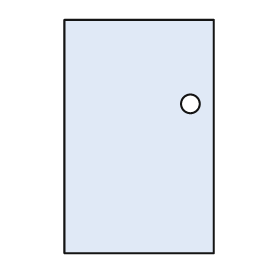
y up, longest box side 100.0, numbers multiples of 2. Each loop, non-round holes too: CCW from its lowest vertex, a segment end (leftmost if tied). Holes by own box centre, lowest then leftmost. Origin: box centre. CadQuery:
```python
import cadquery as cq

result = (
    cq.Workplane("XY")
    .moveTo(-32.0, -50.0)
    .lineTo(32.0, -50.0)
    .lineTo(32.0, 50.0)
    .lineTo(-32.0, 50.0)
    .close()
    .moveTo(22.0, 14.0)
    .circle(4.0)
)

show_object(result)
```